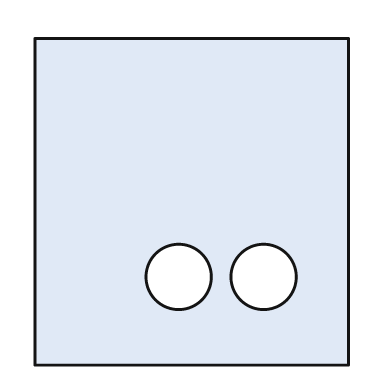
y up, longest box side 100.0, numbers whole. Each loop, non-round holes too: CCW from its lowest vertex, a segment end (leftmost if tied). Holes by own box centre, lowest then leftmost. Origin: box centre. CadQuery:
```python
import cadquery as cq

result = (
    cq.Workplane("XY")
    .moveTo(-48.0, -50.0)
    .lineTo(48.0, -50.0)
    .lineTo(48.0, 50.0)
    .lineTo(-48.0, 50.0)
    .close()
    .moveTo(-4.0, -23.0)
    .circle(10.0)
    .moveTo(22.0, -23.0)
    .circle(10.0)
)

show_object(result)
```